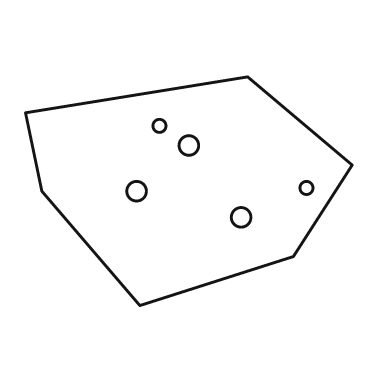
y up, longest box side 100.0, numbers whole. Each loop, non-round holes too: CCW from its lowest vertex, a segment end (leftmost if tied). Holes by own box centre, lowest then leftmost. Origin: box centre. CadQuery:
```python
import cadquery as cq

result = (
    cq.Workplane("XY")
    .moveTo(-15.0, -35.0)
    .lineTo(32.0, -20.0)
    .lineTo(50.0, 8.0)
    .lineTo(18.0, 35.0)
    .lineTo(-50.0, 24.0)
    .lineTo(-45.0, 0.0)
    .close()
    .moveTo(16.0, -8.0)
    .circle(3.0)
    .moveTo(-16.0, 0.0)
    .circle(3.0)
    .moveTo(36.0, 1.0)
    .circle(2.0)
    .moveTo(0.0, 14.0)
    .circle(3.0)
    .moveTo(-9.0, 20.0)
    .circle(2.0)
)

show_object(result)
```